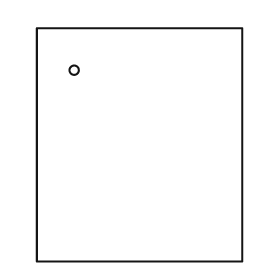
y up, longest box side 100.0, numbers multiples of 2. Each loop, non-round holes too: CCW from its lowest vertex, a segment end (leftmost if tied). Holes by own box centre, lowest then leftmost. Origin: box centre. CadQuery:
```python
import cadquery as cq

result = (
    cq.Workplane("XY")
    .moveTo(-44.0, -50.0)
    .lineTo(44.0, -50.0)
    .lineTo(44.0, 50.0)
    .lineTo(-44.0, 50.0)
    .close()
    .moveTo(-28.0, 32.0)
    .circle(2.0)
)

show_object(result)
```